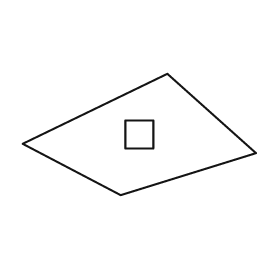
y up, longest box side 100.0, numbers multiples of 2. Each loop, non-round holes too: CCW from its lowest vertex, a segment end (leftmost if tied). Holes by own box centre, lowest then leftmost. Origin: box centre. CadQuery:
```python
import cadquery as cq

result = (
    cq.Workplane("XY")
    .moveTo(-8.0, -26.0)
    .lineTo(50.0, -8.0)
    .lineTo(12.0, 26.0)
    .lineTo(-50.0, -4.0)
    .close()
    .moveTo(-6.0, -6.0)
    .lineTo(6.0, -6.0)
    .lineTo(6.0, 6.0)
    .lineTo(-6.0, 6.0)
    .close()
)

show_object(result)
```